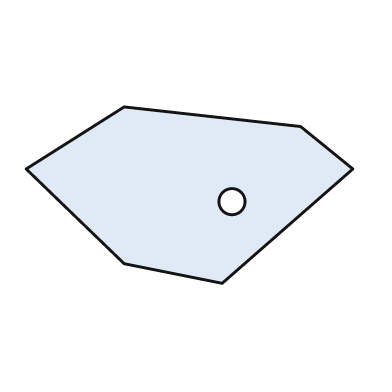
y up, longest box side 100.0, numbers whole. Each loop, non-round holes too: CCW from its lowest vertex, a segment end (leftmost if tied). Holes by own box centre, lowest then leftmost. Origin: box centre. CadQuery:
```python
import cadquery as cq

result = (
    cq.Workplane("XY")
    .moveTo(10.0, -27.0)
    .lineTo(50.0, 8.0)
    .lineTo(34.0, 21.0)
    .lineTo(-20.0, 27.0)
    .lineTo(-50.0, 8.0)
    .lineTo(-20.0, -21.0)
    .close()
    .moveTo(13.0, -2.0)
    .circle(4.0)
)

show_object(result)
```